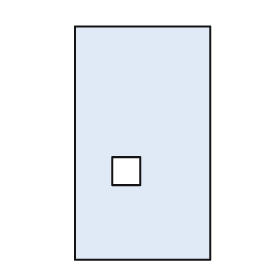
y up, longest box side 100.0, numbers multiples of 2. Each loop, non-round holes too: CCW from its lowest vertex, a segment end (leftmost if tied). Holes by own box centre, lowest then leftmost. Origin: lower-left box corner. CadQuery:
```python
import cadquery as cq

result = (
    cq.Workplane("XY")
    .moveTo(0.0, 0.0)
    .lineTo(58.0, 0.0)
    .lineTo(58.0, 100.0)
    .lineTo(0.0, 100.0)
    .close()
    .moveTo(16.0, 32.0)
    .lineTo(28.0, 32.0)
    .lineTo(28.0, 44.0)
    .lineTo(16.0, 44.0)
    .close()
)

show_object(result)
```